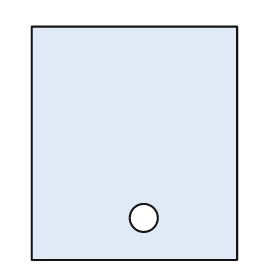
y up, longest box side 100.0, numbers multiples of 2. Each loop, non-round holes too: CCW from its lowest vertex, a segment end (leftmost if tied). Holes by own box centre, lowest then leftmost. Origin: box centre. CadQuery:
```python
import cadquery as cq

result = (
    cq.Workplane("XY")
    .moveTo(-44.0, -50.0)
    .lineTo(44.0, -50.0)
    .lineTo(44.0, 50.0)
    .lineTo(-44.0, 50.0)
    .close()
    .moveTo(4.0, -32.0)
    .circle(6.0)
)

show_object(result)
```